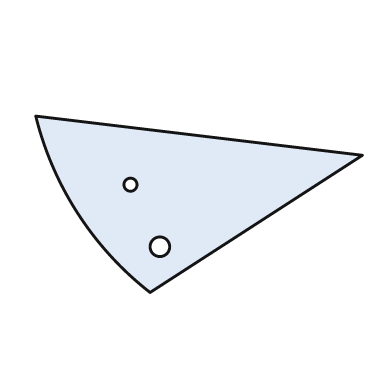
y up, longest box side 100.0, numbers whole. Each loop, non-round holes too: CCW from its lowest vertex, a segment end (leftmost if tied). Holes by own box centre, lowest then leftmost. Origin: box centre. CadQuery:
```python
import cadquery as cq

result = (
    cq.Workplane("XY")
    .moveTo(-15.0, -27.0)
    .lineTo(50.0, 15.0)
    .lineTo(-50.0, 27.0)
    .threePointArc((-37.0, -3.0), (-15.0, -27.0))
    .close()
    .moveTo(-12.0, -13.0)
    .circle(3.0)
    .moveTo(-21.0, 6.0)
    .circle(2.0)
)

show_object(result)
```